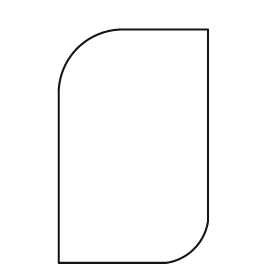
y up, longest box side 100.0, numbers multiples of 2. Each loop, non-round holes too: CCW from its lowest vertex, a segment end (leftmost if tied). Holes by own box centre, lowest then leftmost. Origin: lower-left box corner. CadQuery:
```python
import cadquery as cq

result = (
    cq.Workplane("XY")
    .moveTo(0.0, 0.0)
    .lineTo(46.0, 0.0)
    .threePointArc((58.0, 6.0), (64.0, 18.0))
    .lineTo(64.0, 100.0)
    .lineTo(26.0, 100.0)
    .threePointArc((8.0, 92.0), (0.0, 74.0))
    .close()
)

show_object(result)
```